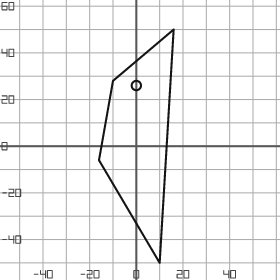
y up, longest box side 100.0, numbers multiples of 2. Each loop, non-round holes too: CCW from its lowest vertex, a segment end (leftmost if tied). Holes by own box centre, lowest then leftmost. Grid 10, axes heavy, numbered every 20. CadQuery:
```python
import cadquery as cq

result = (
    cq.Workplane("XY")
    .moveTo(10.0, -50.0)
    .lineTo(16.0, 50.0)
    .lineTo(-10.0, 28.0)
    .lineTo(-16.0, -6.0)
    .close()
    .moveTo(0.0, 26.0)
    .circle(2.0)
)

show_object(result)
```